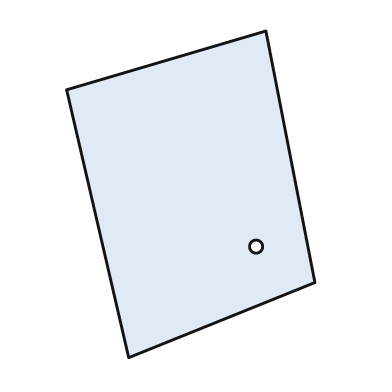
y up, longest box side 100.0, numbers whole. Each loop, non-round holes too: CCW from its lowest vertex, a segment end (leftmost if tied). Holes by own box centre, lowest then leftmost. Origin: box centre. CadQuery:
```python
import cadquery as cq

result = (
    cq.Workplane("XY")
    .moveTo(-19.0, -50.0)
    .lineTo(38.0, -27.0)
    .lineTo(23.0, 50.0)
    .lineTo(-38.0, 32.0)
    .close()
    .moveTo(20.0, -16.0)
    .circle(2.0)
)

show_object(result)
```